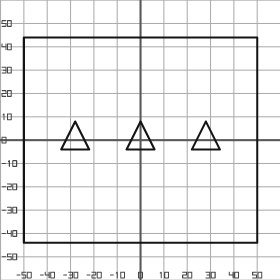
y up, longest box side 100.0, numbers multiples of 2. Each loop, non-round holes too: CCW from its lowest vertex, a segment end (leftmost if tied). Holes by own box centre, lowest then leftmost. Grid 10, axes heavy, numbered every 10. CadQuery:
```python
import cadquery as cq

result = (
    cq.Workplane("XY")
    .moveTo(-50.0, -44.0)
    .lineTo(50.0, -44.0)
    .lineTo(50.0, 44.0)
    .lineTo(-50.0, 44.0)
    .close()
    .moveTo(-34.0, -4.0)
    .lineTo(-22.0, -4.0)
    .lineTo(-28.0, 8.0)
    .close()
    .moveTo(-6.0, -4.0)
    .lineTo(6.0, -4.0)
    .lineTo(0.0, 8.0)
    .close()
    .moveTo(22.0, -4.0)
    .lineTo(34.0, -4.0)
    .lineTo(28.0, 8.0)
    .close()
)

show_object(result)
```